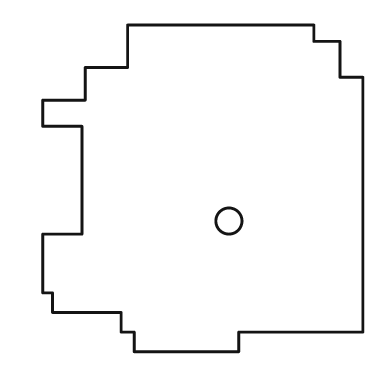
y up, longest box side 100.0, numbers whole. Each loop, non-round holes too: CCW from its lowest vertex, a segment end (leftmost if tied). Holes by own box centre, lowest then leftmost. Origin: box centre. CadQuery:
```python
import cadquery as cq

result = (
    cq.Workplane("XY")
    .moveTo(-21.0, -50.0)
    .lineTo(11.0, -50.0)
    .lineTo(11.0, -44.0)
    .lineTo(49.0, -44.0)
    .lineTo(49.0, 34.0)
    .lineTo(42.0, 34.0)
    .lineTo(42.0, 45.0)
    .lineTo(34.0, 45.0)
    .lineTo(34.0, 50.0)
    .lineTo(-23.0, 50.0)
    .lineTo(-23.0, 37.0)
    .lineTo(-36.0, 37.0)
    .lineTo(-36.0, 27.0)
    .lineTo(-49.0, 27.0)
    .lineTo(-49.0, 19.0)
    .lineTo(-37.0, 19.0)
    .lineTo(-37.0, -14.0)
    .lineTo(-49.0, -14.0)
    .lineTo(-49.0, -32.0)
    .lineTo(-46.0, -32.0)
    .lineTo(-46.0, -38.0)
    .lineTo(-25.0, -38.0)
    .lineTo(-25.0, -44.0)
    .lineTo(-21.0, -44.0)
    .close()
    .moveTo(8.0, -10.0)
    .circle(4.0)
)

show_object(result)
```